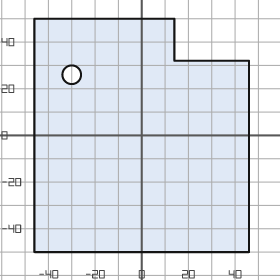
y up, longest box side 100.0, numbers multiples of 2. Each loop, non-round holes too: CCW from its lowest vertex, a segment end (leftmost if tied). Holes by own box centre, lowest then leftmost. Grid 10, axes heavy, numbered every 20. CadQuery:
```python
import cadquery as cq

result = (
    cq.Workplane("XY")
    .moveTo(-46.0, -50.0)
    .lineTo(46.0, -50.0)
    .lineTo(46.0, 32.0)
    .lineTo(14.0, 32.0)
    .lineTo(14.0, 50.0)
    .lineTo(-46.0, 50.0)
    .close()
    .moveTo(-30.0, 26.0)
    .circle(4.0)
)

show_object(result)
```